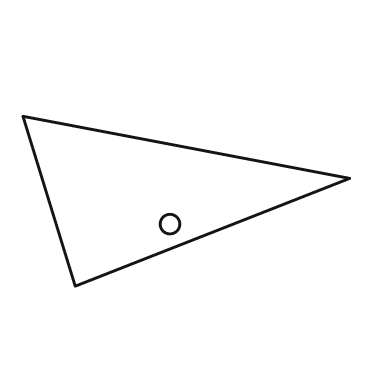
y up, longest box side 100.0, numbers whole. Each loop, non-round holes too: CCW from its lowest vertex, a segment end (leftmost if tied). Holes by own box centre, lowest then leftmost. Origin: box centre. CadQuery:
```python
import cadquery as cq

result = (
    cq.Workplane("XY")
    .moveTo(-34.0, -26.0)
    .lineTo(50.0, 7.0)
    .lineTo(-50.0, 26.0)
    .close()
    .moveTo(-5.0, -7.0)
    .circle(3.0)
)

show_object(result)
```